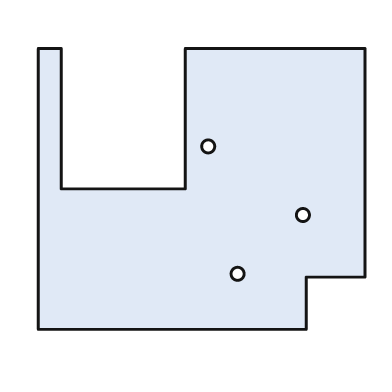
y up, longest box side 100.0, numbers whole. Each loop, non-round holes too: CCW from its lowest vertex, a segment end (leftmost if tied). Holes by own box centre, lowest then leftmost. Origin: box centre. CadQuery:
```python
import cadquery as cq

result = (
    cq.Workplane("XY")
    .moveTo(-50.0, -43.0)
    .lineTo(32.0, -43.0)
    .lineTo(32.0, -27.0)
    .lineTo(50.0, -27.0)
    .lineTo(50.0, 43.0)
    .lineTo(-5.0, 43.0)
    .lineTo(-5.0, 0.0)
    .lineTo(-43.0, 0.0)
    .lineTo(-43.0, 43.0)
    .lineTo(-50.0, 43.0)
    .close()
    .moveTo(11.0, -26.0)
    .circle(2.0)
    .moveTo(31.0, -8.0)
    .circle(2.0)
    .moveTo(2.0, 13.0)
    .circle(2.0)
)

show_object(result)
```